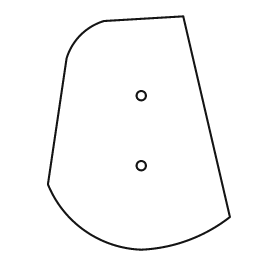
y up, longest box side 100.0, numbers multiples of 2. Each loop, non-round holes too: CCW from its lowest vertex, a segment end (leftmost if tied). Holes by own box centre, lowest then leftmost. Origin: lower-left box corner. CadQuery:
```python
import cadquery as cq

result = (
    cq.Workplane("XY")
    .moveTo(40.0, 0.0)
    .threePointArc((60.0, 4.0), (78.0, 14.0))
    .lineTo(58.0, 100.0)
    .lineTo(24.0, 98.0)
    .threePointArc((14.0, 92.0), (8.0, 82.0))
    .lineTo(0.0, 28.0)
    .threePointArc((16.0, 8.0), (40.0, 0.0))
    .close()
    .moveTo(40.0, 36.0)
    .circle(2.0)
    .moveTo(40.0, 66.0)
    .circle(2.0)
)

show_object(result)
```